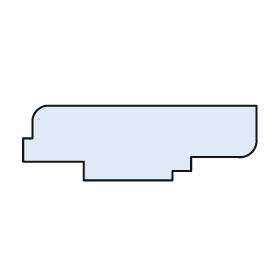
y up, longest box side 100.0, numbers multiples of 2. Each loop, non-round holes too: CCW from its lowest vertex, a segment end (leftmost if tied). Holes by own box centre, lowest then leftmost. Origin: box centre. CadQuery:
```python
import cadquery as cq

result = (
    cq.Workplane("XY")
    .moveTo(-24.0, -16.0)
    .lineTo(14.0, -16.0)
    .lineTo(14.0, -12.0)
    .lineTo(22.0, -12.0)
    .lineTo(22.0, -6.0)
    .lineTo(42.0, -6.0)
    .threePointArc((48.0, -4.0), (50.0, 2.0))
    .lineTo(50.0, 16.0)
    .lineTo(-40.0, 16.0)
    .threePointArc((-44.0, 14.0), (-46.0, 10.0))
    .lineTo(-46.0, 2.0)
    .lineTo(-50.0, 2.0)
    .lineTo(-50.0, -8.0)
    .lineTo(-24.0, -8.0)
    .close()
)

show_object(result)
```